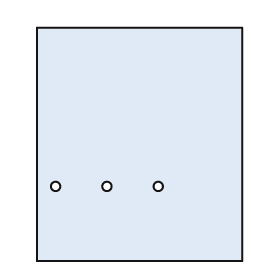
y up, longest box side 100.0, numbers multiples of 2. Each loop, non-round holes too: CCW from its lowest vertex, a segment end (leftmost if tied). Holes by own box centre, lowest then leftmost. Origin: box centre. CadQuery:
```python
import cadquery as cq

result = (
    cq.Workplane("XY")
    .moveTo(-44.0, -50.0)
    .lineTo(44.0, -50.0)
    .lineTo(44.0, 50.0)
    .lineTo(-44.0, 50.0)
    .close()
    .moveTo(-36.0, -18.0)
    .circle(2.0)
    .moveTo(-14.0, -18.0)
    .circle(2.0)
    .moveTo(8.0, -18.0)
    .circle(2.0)
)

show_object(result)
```